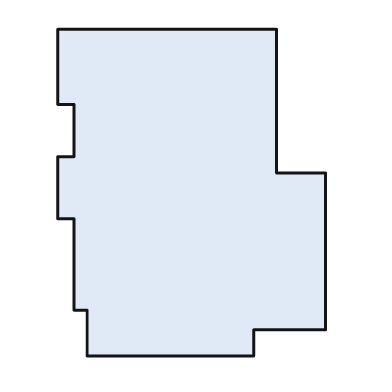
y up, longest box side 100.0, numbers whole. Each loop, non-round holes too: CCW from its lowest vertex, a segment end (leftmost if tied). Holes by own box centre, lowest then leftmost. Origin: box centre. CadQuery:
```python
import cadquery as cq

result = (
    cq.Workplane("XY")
    .moveTo(-32.0, -50.0)
    .lineTo(19.0, -50.0)
    .lineTo(19.0, -42.0)
    .lineTo(41.0, -42.0)
    .lineTo(41.0, 6.0)
    .lineTo(26.0, 6.0)
    .lineTo(26.0, 50.0)
    .lineTo(-41.0, 50.0)
    .lineTo(-41.0, 27.0)
    .lineTo(-36.0, 27.0)
    .lineTo(-36.0, 11.0)
    .lineTo(-41.0, 11.0)
    .lineTo(-41.0, -8.0)
    .lineTo(-36.0, -8.0)
    .lineTo(-36.0, -36.0)
    .lineTo(-32.0, -36.0)
    .close()
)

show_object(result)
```